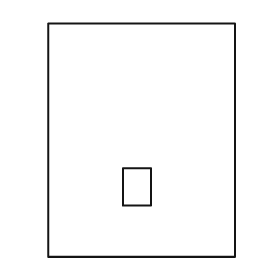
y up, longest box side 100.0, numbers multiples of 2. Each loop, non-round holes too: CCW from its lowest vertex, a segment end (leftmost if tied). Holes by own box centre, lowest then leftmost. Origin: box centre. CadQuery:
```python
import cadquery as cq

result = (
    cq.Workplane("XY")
    .moveTo(-40.0, -50.0)
    .lineTo(40.0, -50.0)
    .lineTo(40.0, 50.0)
    .lineTo(-40.0, 50.0)
    .close()
    .moveTo(-8.0, -28.0)
    .lineTo(4.0, -28.0)
    .lineTo(4.0, -12.0)
    .lineTo(-8.0, -12.0)
    .close()
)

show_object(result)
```